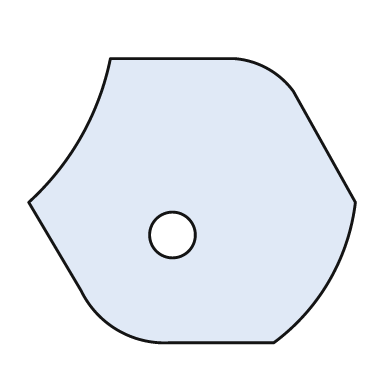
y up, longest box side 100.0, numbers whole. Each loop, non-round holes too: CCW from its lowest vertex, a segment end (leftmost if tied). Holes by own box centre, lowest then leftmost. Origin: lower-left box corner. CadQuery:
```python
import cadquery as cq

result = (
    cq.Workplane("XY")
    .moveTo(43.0, 0.0)
    .lineTo(75.0, 0.0)
    .threePointArc((92.0, 19.0), (100.0, 43.0))
    .lineTo(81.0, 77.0)
    .threePointArc((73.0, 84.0), (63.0, 87.0))
    .lineTo(25.0, 87.0)
    .threePointArc((16.0, 63.0), (0.0, 43.0))
    .lineTo(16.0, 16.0)
    .threePointArc((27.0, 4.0), (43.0, 0.0))
    .close()
    .moveTo(44.0, 33.0)
    .circle(7.0)
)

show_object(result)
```